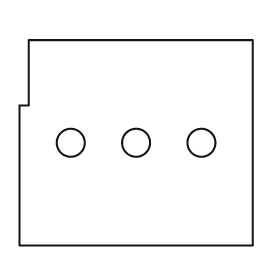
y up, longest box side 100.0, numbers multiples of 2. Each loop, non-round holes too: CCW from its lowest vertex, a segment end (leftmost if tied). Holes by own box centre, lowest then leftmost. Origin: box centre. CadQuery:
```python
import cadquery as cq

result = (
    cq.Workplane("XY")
    .moveTo(-50.0, -44.0)
    .lineTo(50.0, -44.0)
    .lineTo(50.0, 44.0)
    .lineTo(-46.0, 44.0)
    .lineTo(-46.0, 16.0)
    .lineTo(-50.0, 16.0)
    .close()
    .moveTo(-28.0, 0.0)
    .circle(6.0)
    .moveTo(0.0, 0.0)
    .circle(6.0)
    .moveTo(28.0, 0.0)
    .circle(6.0)
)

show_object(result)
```